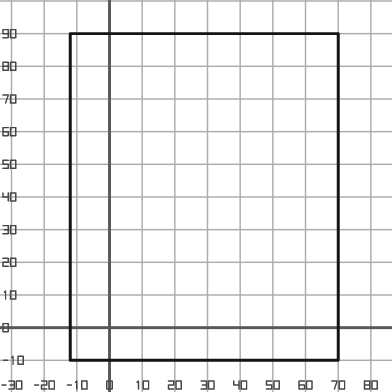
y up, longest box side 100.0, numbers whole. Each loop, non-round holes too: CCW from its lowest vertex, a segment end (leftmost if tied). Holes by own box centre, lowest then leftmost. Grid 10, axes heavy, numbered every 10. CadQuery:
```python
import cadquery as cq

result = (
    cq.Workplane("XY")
    .moveTo(-12.0, -10.0)
    .lineTo(70.0, -10.0)
    .lineTo(70.0, 90.0)
    .lineTo(-12.0, 90.0)
    .close()
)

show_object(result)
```